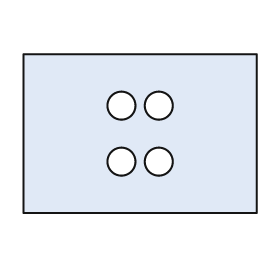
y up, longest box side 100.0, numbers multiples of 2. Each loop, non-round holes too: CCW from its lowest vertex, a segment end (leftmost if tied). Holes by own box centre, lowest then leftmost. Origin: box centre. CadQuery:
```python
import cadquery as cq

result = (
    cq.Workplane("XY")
    .moveTo(-50.0, -34.0)
    .lineTo(50.0, -34.0)
    .lineTo(50.0, 34.0)
    .lineTo(-50.0, 34.0)
    .close()
    .moveTo(-8.0, -12.0)
    .circle(6.0)
    .moveTo(8.0, -12.0)
    .circle(6.0)
    .moveTo(-8.0, 12.0)
    .circle(6.0)
    .moveTo(8.0, 12.0)
    .circle(6.0)
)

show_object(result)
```